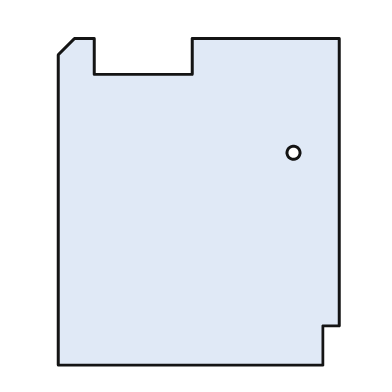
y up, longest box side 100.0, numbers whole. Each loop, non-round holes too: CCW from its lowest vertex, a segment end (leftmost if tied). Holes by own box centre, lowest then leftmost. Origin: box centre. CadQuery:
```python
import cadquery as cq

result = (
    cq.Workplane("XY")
    .moveTo(-43.0, -50.0)
    .lineTo(38.0, -50.0)
    .lineTo(38.0, -38.0)
    .lineTo(43.0, -38.0)
    .lineTo(43.0, 50.0)
    .lineTo(-2.0, 50.0)
    .lineTo(-2.0, 39.0)
    .lineTo(-32.0, 39.0)
    .lineTo(-32.0, 50.0)
    .lineTo(-38.0, 50.0)
    .lineTo(-43.0, 45.0)
    .close()
    .moveTo(29.0, 15.0)
    .circle(2.0)
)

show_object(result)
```